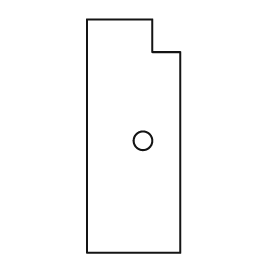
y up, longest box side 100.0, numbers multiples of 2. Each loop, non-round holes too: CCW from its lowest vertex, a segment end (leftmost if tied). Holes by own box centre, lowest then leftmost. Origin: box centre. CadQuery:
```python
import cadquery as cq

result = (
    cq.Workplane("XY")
    .moveTo(-20.0, -50.0)
    .lineTo(20.0, -50.0)
    .lineTo(20.0, 36.0)
    .lineTo(8.0, 36.0)
    .lineTo(8.0, 50.0)
    .lineTo(-20.0, 50.0)
    .close()
    .moveTo(4.0, -2.0)
    .circle(4.0)
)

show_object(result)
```